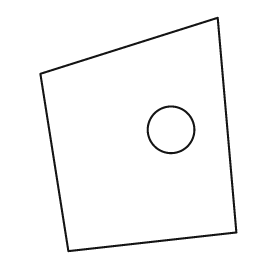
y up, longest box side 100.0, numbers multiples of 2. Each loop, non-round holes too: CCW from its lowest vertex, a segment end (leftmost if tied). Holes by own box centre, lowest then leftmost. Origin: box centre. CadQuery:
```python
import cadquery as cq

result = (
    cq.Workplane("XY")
    .moveTo(-30.0, -50.0)
    .lineTo(42.0, -42.0)
    .lineTo(34.0, 50.0)
    .lineTo(-42.0, 26.0)
    .close()
    .moveTo(14.0, 2.0)
    .circle(10.0)
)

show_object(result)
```